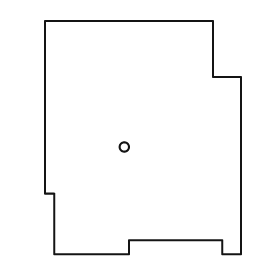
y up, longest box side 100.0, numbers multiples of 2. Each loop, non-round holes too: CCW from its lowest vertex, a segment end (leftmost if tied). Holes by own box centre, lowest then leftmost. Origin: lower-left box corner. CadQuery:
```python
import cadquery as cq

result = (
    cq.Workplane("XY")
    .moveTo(4.0, 0.0)
    .lineTo(36.0, 0.0)
    .lineTo(36.0, 6.0)
    .lineTo(76.0, 6.0)
    .lineTo(76.0, 0.0)
    .lineTo(84.0, 0.0)
    .lineTo(84.0, 76.0)
    .lineTo(72.0, 76.0)
    .lineTo(72.0, 100.0)
    .lineTo(0.0, 100.0)
    .lineTo(0.0, 26.0)
    .lineTo(4.0, 26.0)
    .close()
    .moveTo(34.0, 46.0)
    .circle(2.0)
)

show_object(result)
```